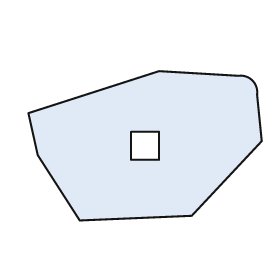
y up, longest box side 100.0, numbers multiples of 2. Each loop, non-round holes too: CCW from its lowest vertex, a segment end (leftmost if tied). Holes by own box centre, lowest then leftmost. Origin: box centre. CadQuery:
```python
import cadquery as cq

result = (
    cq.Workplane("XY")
    .moveTo(-28.0, -32.0)
    .lineTo(20.0, -30.0)
    .lineTo(50.0, 2.0)
    .lineTo(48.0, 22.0)
    .threePointArc((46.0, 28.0), (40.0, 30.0))
    .lineTo(6.0, 32.0)
    .lineTo(-50.0, 14.0)
    .lineTo(-46.0, -4.0)
    .close()
    .moveTo(-6.0, -6.0)
    .lineTo(6.0, -6.0)
    .lineTo(6.0, 6.0)
    .lineTo(-6.0, 6.0)
    .close()
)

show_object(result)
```